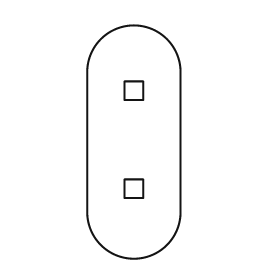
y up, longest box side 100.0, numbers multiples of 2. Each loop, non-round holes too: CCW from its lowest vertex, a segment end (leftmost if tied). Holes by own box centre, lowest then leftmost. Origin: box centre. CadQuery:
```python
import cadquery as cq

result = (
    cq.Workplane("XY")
    .moveTo(-20.0, -30.0)
    .threePointArc((0.0, -50.0), (20.0, -30.0))
    .lineTo(20.0, 30.0)
    .threePointArc((0.0, 50.0), (-20.0, 30.0))
    .close()
    .moveTo(-4.0, -24.0)
    .lineTo(4.0, -24.0)
    .lineTo(4.0, -16.0)
    .lineTo(-4.0, -16.0)
    .close()
    .moveTo(-4.0, 18.0)
    .lineTo(4.0, 18.0)
    .lineTo(4.0, 26.0)
    .lineTo(-4.0, 26.0)
    .close()
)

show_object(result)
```